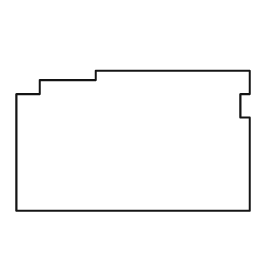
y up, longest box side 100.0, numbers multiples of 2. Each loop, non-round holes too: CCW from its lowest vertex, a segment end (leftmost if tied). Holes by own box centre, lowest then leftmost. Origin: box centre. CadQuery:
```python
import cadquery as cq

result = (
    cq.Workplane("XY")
    .moveTo(-50.0, -30.0)
    .lineTo(50.0, -30.0)
    .lineTo(50.0, 10.0)
    .lineTo(46.0, 10.0)
    .lineTo(46.0, 20.0)
    .lineTo(50.0, 20.0)
    .lineTo(50.0, 30.0)
    .lineTo(-16.0, 30.0)
    .lineTo(-16.0, 26.0)
    .lineTo(-40.0, 26.0)
    .lineTo(-40.0, 20.0)
    .lineTo(-50.0, 20.0)
    .close()
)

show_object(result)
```